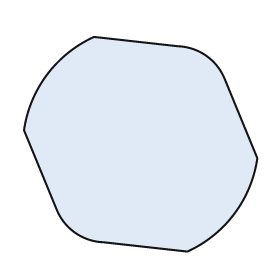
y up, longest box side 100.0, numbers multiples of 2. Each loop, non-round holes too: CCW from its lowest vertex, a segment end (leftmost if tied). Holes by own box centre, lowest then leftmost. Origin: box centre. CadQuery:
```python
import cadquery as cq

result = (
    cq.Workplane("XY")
    .moveTo(20.0, -46.0)
    .threePointArc((40.0, -30.0), (50.0, -6.0))
    .lineTo(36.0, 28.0)
    .threePointArc((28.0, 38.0), (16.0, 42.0))
    .lineTo(-20.0, 46.0)
    .threePointArc((-40.0, 30.0), (-50.0, 6.0))
    .lineTo(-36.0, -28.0)
    .threePointArc((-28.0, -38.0), (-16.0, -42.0))
    .close()
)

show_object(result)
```